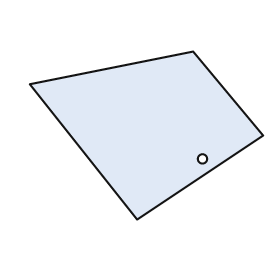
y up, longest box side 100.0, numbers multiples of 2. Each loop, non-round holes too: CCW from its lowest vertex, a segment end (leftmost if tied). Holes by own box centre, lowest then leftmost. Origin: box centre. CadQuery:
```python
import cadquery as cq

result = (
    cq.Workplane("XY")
    .moveTo(-4.0, -36.0)
    .lineTo(50.0, 0.0)
    .lineTo(20.0, 36.0)
    .lineTo(-50.0, 22.0)
    .close()
    .moveTo(24.0, -10.0)
    .circle(2.0)
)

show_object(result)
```